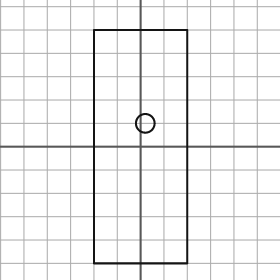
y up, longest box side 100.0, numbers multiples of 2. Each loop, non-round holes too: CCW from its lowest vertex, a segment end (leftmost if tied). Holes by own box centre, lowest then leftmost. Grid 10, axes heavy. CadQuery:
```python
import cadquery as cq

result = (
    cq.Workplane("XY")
    .moveTo(-20.0, -50.0)
    .lineTo(20.0, -50.0)
    .lineTo(20.0, 50.0)
    .lineTo(-20.0, 50.0)
    .close()
    .moveTo(2.0, 10.0)
    .circle(4.0)
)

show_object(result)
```